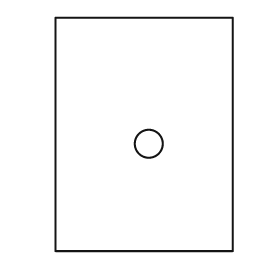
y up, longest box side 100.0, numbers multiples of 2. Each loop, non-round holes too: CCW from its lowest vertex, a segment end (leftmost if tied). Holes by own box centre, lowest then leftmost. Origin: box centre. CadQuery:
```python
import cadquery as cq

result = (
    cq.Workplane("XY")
    .moveTo(-38.0, -50.0)
    .lineTo(38.0, -50.0)
    .lineTo(38.0, 50.0)
    .lineTo(-38.0, 50.0)
    .close()
    .moveTo(2.0, -4.0)
    .circle(6.0)
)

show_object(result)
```